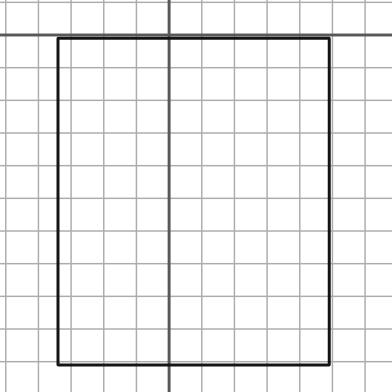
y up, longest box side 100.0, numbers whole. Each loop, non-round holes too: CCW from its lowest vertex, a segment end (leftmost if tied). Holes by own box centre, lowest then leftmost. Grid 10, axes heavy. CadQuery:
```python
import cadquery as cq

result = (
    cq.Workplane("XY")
    .moveTo(-34.0, -101.0)
    .lineTo(49.0, -101.0)
    .lineTo(49.0, -1.0)
    .lineTo(-34.0, -1.0)
    .close()
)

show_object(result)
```